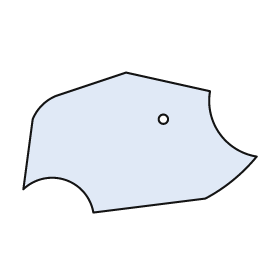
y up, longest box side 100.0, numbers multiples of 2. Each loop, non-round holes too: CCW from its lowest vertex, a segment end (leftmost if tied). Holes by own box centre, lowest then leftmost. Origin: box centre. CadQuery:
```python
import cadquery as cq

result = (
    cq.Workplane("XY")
    .moveTo(-20.0, -30.0)
    .lineTo(28.0, -24.0)
    .threePointArc((40.0, -16.0), (50.0, -6.0))
    .threePointArc((34.0, 4.0), (30.0, 22.0))
    .lineTo(-6.0, 30.0)
    .lineTo(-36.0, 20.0)
    .threePointArc((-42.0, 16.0), (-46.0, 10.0))
    .lineTo(-50.0, -20.0)
    .threePointArc((-32.0, -16.0), (-20.0, -30.0))
    .close()
    .moveTo(10.0, 10.0)
    .circle(2.0)
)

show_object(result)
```